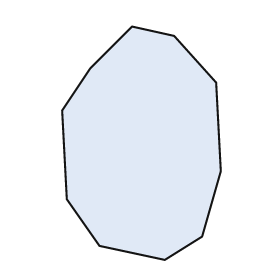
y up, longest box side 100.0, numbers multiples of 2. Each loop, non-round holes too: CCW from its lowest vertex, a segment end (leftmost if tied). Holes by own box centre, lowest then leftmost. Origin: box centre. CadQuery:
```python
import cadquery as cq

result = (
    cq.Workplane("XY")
    .moveTo(10.0, -50.0)
    .lineTo(26.0, -40.0)
    .lineTo(34.0, -12.0)
    .lineTo(32.0, 26.0)
    .lineTo(14.0, 46.0)
    .lineTo(-4.0, 50.0)
    .lineTo(-22.0, 32.0)
    .lineTo(-34.0, 14.0)
    .lineTo(-32.0, -24.0)
    .lineTo(-18.0, -44.0)
    .close()
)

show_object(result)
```